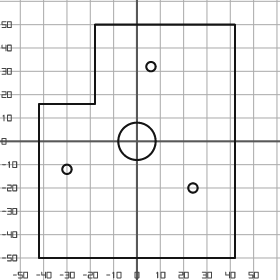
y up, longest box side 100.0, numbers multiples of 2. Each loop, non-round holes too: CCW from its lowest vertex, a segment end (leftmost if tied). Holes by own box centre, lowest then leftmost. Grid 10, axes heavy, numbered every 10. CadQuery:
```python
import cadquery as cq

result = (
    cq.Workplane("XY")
    .moveTo(-42.0, -50.0)
    .lineTo(42.0, -50.0)
    .lineTo(42.0, 50.0)
    .lineTo(-18.0, 50.0)
    .lineTo(-18.0, 16.0)
    .lineTo(-42.0, 16.0)
    .close()
    .moveTo(24.0, -20.0)
    .circle(2.0)
    .moveTo(-30.0, -12.0)
    .circle(2.0)
    .moveTo(0.0, 0.0)
    .circle(8.0)
    .moveTo(6.0, 32.0)
    .circle(2.0)
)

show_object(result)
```